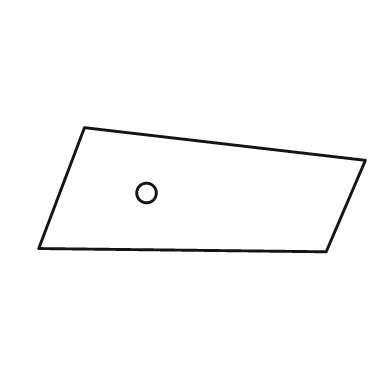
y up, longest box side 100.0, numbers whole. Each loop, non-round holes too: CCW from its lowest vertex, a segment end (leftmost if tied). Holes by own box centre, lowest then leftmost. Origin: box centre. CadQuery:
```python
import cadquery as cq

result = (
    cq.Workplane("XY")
    .moveTo(38.0, -19.0)
    .lineTo(50.0, 9.0)
    .lineTo(-36.0, 19.0)
    .lineTo(-50.0, -18.0)
    .close()
    .moveTo(-17.0, -1.0)
    .circle(3.0)
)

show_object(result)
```